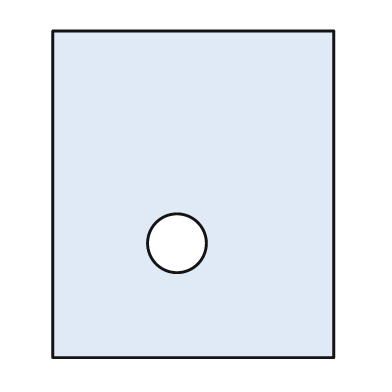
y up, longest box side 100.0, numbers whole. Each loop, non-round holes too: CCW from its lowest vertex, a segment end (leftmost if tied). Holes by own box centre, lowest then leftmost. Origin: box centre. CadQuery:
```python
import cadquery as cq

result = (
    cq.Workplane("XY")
    .moveTo(-43.0, -50.0)
    .lineTo(43.0, -50.0)
    .lineTo(43.0, 50.0)
    .lineTo(-43.0, 50.0)
    .close()
    .moveTo(-5.0, -15.0)
    .circle(9.0)
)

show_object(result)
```